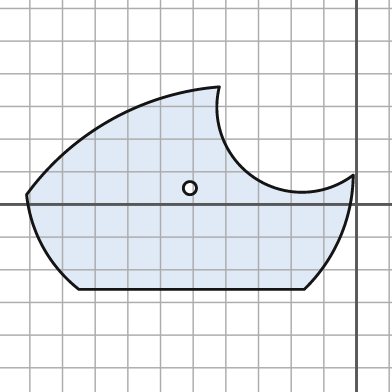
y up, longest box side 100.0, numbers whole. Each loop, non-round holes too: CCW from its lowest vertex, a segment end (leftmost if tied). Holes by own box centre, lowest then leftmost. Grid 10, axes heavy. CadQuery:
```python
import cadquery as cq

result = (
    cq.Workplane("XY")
    .moveTo(-85.0, -26.0)
    .lineTo(-16.0, -26.0)
    .threePointArc((-5.0, -10.0), (-1.0, 9.0))
    .threePointArc((-31.0, 8.0), (-42.0, 36.0))
    .threePointArc((-75.0, 26.0), (-101.0, 3.0))
    .threePointArc((-96.0, -13.0), (-85.0, -26.0))
    .close()
    .moveTo(-51.0, 5.0)
    .circle(2.0)
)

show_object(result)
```